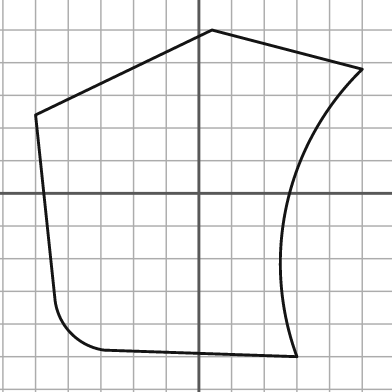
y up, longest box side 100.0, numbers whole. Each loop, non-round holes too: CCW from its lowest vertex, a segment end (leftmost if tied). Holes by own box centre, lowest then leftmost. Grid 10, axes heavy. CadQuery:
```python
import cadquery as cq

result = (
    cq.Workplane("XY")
    .moveTo(30.0, -50.0)
    .threePointArc((27.0, -3.0), (50.0, 38.0))
    .lineTo(4.0, 50.0)
    .lineTo(-50.0, 24.0)
    .lineTo(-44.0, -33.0)
    .threePointArc((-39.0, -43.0), (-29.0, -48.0))
    .close()
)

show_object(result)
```